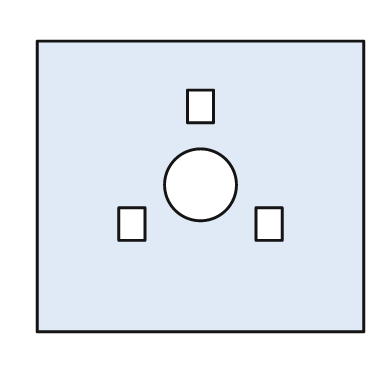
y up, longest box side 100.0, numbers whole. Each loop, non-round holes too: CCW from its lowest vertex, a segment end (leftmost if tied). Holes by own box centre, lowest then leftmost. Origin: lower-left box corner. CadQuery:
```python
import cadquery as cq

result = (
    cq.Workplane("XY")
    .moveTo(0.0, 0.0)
    .lineTo(100.0, 0.0)
    .lineTo(100.0, 89.0)
    .lineTo(0.0, 89.0)
    .close()
    .moveTo(25.0, 28.0)
    .lineTo(33.0, 28.0)
    .lineTo(33.0, 38.0)
    .lineTo(25.0, 38.0)
    .close()
    .moveTo(67.0, 28.0)
    .lineTo(75.0, 28.0)
    .lineTo(75.0, 38.0)
    .lineTo(67.0, 38.0)
    .close()
    .moveTo(50.0, 45.0)
    .circle(11.0)
    .moveTo(46.0, 64.0)
    .lineTo(54.0, 64.0)
    .lineTo(54.0, 74.0)
    .lineTo(46.0, 74.0)
    .close()
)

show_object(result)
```